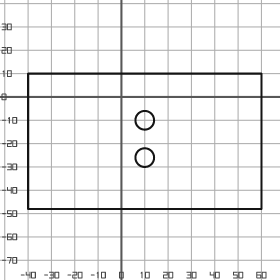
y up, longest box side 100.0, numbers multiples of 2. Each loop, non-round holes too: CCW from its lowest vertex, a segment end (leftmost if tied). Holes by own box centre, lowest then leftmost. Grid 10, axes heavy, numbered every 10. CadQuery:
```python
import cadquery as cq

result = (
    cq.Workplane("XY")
    .moveTo(-40.0, -48.0)
    .lineTo(60.0, -48.0)
    .lineTo(60.0, 10.0)
    .lineTo(-40.0, 10.0)
    .close()
    .moveTo(10.0, -26.0)
    .circle(4.0)
    .moveTo(10.0, -10.0)
    .circle(4.0)
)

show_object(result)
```